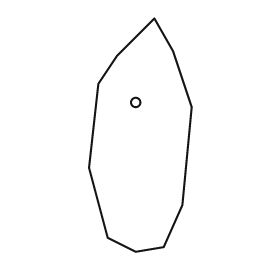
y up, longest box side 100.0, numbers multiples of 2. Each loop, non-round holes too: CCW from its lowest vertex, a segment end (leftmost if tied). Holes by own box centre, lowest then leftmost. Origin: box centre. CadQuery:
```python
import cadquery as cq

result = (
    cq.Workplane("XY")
    .moveTo(-2.0, -50.0)
    .lineTo(10.0, -48.0)
    .lineTo(18.0, -30.0)
    .lineTo(22.0, 12.0)
    .lineTo(14.0, 36.0)
    .lineTo(6.0, 50.0)
    .lineTo(-10.0, 34.0)
    .lineTo(-18.0, 22.0)
    .lineTo(-22.0, -14.0)
    .lineTo(-14.0, -44.0)
    .close()
    .moveTo(-2.0, 14.0)
    .circle(2.0)
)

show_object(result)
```